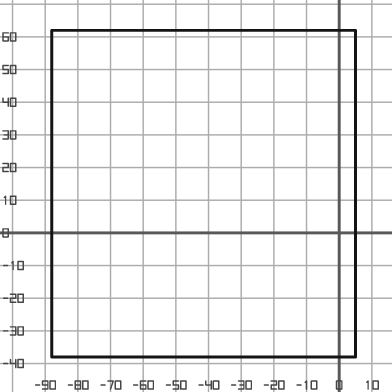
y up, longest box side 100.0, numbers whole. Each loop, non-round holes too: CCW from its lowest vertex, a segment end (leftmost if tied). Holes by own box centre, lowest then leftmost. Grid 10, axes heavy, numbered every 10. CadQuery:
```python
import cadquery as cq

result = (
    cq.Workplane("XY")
    .moveTo(-88.0, -38.0)
    .lineTo(5.0, -38.0)
    .lineTo(5.0, 62.0)
    .lineTo(-88.0, 62.0)
    .close()
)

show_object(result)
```